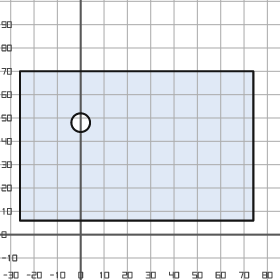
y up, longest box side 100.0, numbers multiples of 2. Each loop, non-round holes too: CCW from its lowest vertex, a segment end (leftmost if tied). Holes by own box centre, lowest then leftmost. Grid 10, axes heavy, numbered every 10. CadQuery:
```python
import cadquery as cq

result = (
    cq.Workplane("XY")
    .moveTo(-26.0, 6.0)
    .lineTo(74.0, 6.0)
    .lineTo(74.0, 70.0)
    .lineTo(-26.0, 70.0)
    .close()
    .moveTo(0.0, 48.0)
    .circle(4.0)
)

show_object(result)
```